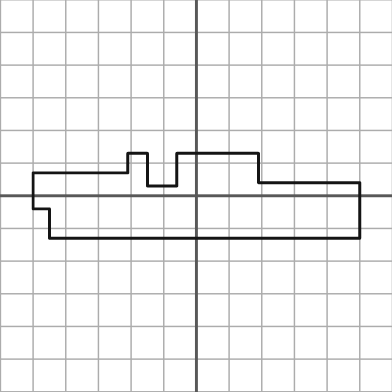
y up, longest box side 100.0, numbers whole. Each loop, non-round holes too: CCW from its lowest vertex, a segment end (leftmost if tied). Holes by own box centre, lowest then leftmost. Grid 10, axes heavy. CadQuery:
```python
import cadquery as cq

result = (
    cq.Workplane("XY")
    .moveTo(-45.0, -13.0)
    .lineTo(50.0, -13.0)
    .lineTo(50.0, 4.0)
    .lineTo(19.0, 4.0)
    .lineTo(19.0, 13.0)
    .lineTo(-6.0, 13.0)
    .lineTo(-6.0, 3.0)
    .lineTo(-15.0, 3.0)
    .lineTo(-15.0, 13.0)
    .lineTo(-21.0, 13.0)
    .lineTo(-21.0, 7.0)
    .lineTo(-50.0, 7.0)
    .lineTo(-50.0, -4.0)
    .lineTo(-45.0, -4.0)
    .close()
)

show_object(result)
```